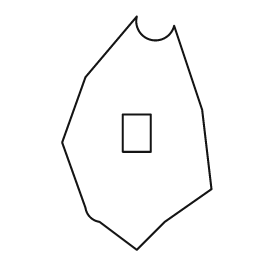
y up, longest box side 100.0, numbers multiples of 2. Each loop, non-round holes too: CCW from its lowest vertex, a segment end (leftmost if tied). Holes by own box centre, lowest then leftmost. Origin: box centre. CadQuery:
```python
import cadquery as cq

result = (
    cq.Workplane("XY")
    .moveTo(0.0, -50.0)
    .lineTo(12.0, -38.0)
    .lineTo(32.0, -24.0)
    .lineTo(28.0, 10.0)
    .lineTo(16.0, 46.0)
    .threePointArc((6.0, 40.0), (0.0, 50.0))
    .lineTo(-22.0, 24.0)
    .lineTo(-32.0, -4.0)
    .lineTo(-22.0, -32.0)
    .threePointArc((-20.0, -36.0), (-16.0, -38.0))
    .close()
    .moveTo(-6.0, -8.0)
    .lineTo(6.0, -8.0)
    .lineTo(6.0, 8.0)
    .lineTo(-6.0, 8.0)
    .close()
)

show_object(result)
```